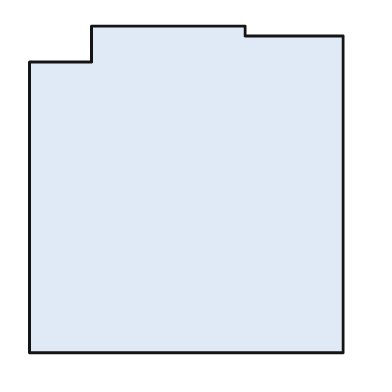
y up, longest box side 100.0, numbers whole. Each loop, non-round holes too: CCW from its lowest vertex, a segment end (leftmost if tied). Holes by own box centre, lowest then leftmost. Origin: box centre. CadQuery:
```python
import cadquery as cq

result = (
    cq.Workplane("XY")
    .moveTo(-48.0, -50.0)
    .lineTo(48.0, -50.0)
    .lineTo(48.0, 47.0)
    .lineTo(18.0, 47.0)
    .lineTo(18.0, 50.0)
    .lineTo(-29.0, 50.0)
    .lineTo(-29.0, 39.0)
    .lineTo(-48.0, 39.0)
    .close()
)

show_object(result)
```